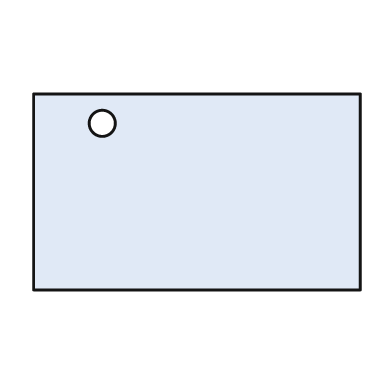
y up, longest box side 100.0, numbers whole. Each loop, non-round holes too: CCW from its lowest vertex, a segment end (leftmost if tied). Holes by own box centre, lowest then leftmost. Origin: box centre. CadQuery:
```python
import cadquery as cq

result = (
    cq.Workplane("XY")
    .moveTo(-50.0, -30.0)
    .lineTo(50.0, -30.0)
    .lineTo(50.0, 30.0)
    .lineTo(-50.0, 30.0)
    .close()
    .moveTo(-29.0, 21.0)
    .circle(4.0)
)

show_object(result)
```